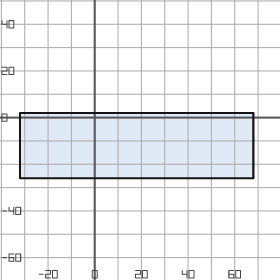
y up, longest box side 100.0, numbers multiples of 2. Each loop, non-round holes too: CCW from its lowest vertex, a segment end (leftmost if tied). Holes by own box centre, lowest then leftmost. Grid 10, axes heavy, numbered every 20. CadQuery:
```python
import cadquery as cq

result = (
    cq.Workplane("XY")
    .moveTo(-32.0, -26.0)
    .lineTo(68.0, -26.0)
    .lineTo(68.0, 2.0)
    .lineTo(-32.0, 2.0)
    .close()
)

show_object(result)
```